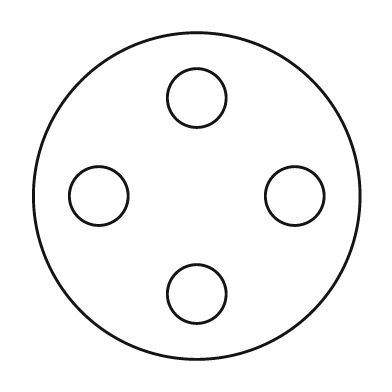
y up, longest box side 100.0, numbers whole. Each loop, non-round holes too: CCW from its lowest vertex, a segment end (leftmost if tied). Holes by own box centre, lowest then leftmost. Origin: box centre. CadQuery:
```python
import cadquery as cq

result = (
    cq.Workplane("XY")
    .moveTo(0.0, 0.0)
    .circle(50.0)
    .moveTo(0.0, -30.0)
    .circle(9.0)
    .moveTo(-30.0, 0.0)
    .circle(9.0)
    .moveTo(30.0, 0.0)
    .circle(9.0)
    .moveTo(0.0, 30.0)
    .circle(9.0)
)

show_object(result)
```